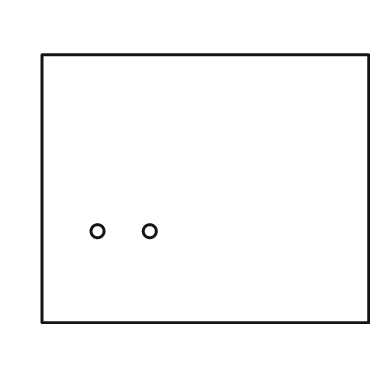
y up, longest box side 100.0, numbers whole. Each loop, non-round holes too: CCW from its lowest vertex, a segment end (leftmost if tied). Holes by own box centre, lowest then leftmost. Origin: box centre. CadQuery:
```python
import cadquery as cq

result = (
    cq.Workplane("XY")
    .moveTo(-50.0, -41.0)
    .lineTo(50.0, -41.0)
    .lineTo(50.0, 41.0)
    .lineTo(-50.0, 41.0)
    .close()
    .moveTo(-33.0, -13.0)
    .circle(2.0)
    .moveTo(-17.0, -13.0)
    .circle(2.0)
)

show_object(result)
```